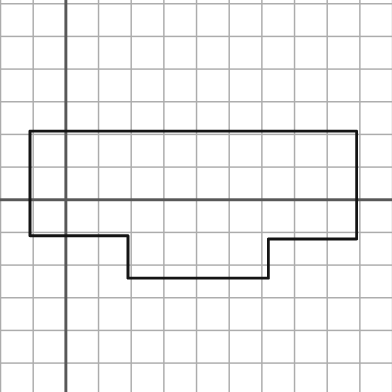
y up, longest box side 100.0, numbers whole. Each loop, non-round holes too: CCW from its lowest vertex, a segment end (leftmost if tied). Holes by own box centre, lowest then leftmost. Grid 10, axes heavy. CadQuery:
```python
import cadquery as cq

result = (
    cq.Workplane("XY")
    .moveTo(19.0, -24.0)
    .lineTo(62.0, -24.0)
    .lineTo(62.0, -12.0)
    .lineTo(89.0, -12.0)
    .lineTo(89.0, 21.0)
    .lineTo(-11.0, 21.0)
    .lineTo(-11.0, -11.0)
    .lineTo(19.0, -11.0)
    .close()
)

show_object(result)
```